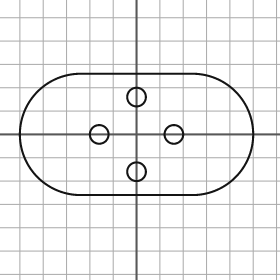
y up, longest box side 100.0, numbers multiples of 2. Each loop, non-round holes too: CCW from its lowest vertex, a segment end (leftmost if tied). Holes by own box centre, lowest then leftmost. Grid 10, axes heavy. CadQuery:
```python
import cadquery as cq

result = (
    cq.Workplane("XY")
    .moveTo(-24.0, -26.0)
    .lineTo(24.0, -26.0)
    .threePointArc((50.0, 0.0), (24.0, 26.0))
    .lineTo(-24.0, 26.0)
    .threePointArc((-50.0, 0.0), (-24.0, -26.0))
    .close()
    .moveTo(0.0, -16.0)
    .circle(4.0)
    .moveTo(-16.0, 0.0)
    .circle(4.0)
    .moveTo(16.0, 0.0)
    .circle(4.0)
    .moveTo(0.0, 16.0)
    .circle(4.0)
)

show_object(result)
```